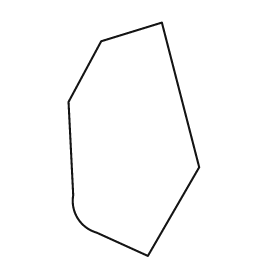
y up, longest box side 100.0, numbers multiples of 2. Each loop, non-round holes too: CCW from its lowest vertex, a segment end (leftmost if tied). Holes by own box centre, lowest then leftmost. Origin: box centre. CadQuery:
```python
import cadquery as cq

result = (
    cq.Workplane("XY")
    .moveTo(6.0, -50.0)
    .lineTo(28.0, -12.0)
    .lineTo(12.0, 50.0)
    .lineTo(-14.0, 42.0)
    .lineTo(-28.0, 16.0)
    .lineTo(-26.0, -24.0)
    .threePointArc((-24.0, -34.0), (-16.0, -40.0))
    .close()
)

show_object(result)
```